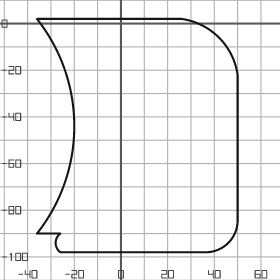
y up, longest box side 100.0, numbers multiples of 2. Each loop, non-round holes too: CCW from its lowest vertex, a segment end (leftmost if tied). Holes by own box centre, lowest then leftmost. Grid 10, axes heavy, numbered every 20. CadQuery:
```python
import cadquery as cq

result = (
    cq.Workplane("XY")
    .moveTo(-26.0, -98.0)
    .lineTo(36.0, -98.0)
    .threePointArc((46.0, -94.0), (50.0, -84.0))
    .lineTo(50.0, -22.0)
    .threePointArc((42.0, -6.0), (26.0, 2.0))
    .lineTo(-36.0, 2.0)
    .threePointArc((-20.0, -44.0), (-36.0, -90.0))
    .lineTo(-26.0, -90.0)
    .threePointArc((-28.0, -94.0), (-26.0, -98.0))
    .close()
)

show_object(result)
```